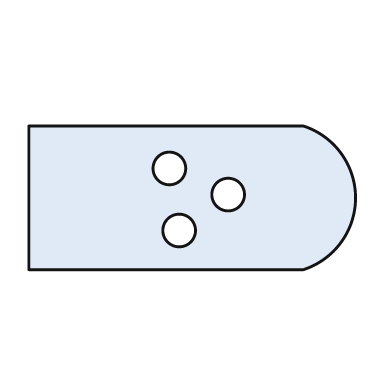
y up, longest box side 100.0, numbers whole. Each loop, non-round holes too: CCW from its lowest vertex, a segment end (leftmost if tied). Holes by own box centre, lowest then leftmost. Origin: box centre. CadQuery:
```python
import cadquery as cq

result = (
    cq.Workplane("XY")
    .moveTo(-50.0, -22.0)
    .lineTo(34.0, -22.0)
    .threePointArc((50.0, 0.0), (34.0, 22.0))
    .lineTo(-50.0, 22.0)
    .close()
    .moveTo(-4.0, -10.0)
    .circle(5.0)
    .moveTo(11.0, 1.0)
    .circle(5.0)
    .moveTo(-7.0, 9.0)
    .circle(5.0)
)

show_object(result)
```